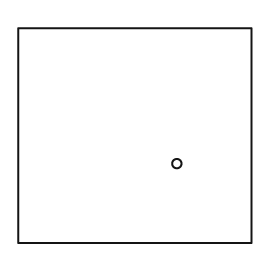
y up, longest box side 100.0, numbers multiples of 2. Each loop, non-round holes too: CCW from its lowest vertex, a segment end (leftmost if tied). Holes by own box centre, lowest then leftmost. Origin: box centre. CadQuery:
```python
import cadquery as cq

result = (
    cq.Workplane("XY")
    .moveTo(-50.0, -46.0)
    .lineTo(50.0, -46.0)
    .lineTo(50.0, 46.0)
    .lineTo(-50.0, 46.0)
    .close()
    .moveTo(18.0, -12.0)
    .circle(2.0)
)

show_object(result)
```